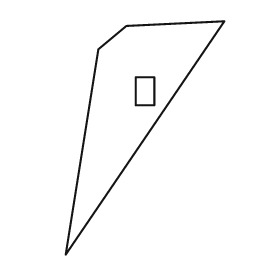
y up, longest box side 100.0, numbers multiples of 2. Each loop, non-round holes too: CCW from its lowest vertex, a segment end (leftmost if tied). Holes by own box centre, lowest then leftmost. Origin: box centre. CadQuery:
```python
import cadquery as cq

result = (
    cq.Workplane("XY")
    .moveTo(-34.0, -50.0)
    .lineTo(34.0, 50.0)
    .lineTo(-8.0, 48.0)
    .lineTo(-20.0, 38.0)
    .close()
    .moveTo(-4.0, 14.0)
    .lineTo(4.0, 14.0)
    .lineTo(4.0, 26.0)
    .lineTo(-4.0, 26.0)
    .close()
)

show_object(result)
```